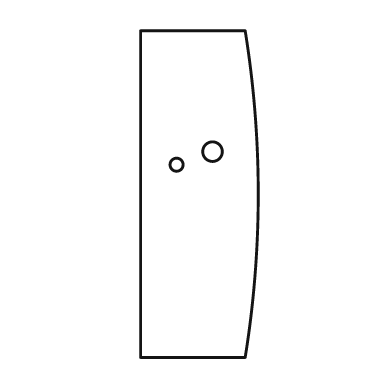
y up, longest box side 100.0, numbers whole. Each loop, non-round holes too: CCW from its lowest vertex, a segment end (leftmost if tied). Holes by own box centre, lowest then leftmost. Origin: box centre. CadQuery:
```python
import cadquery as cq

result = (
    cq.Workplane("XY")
    .moveTo(-18.0, -50.0)
    .lineTo(14.0, -50.0)
    .threePointArc((18.0, 0.0), (14.0, 50.0))
    .lineTo(-18.0, 50.0)
    .close()
    .moveTo(-7.0, 9.0)
    .circle(2.0)
    .moveTo(4.0, 13.0)
    .circle(3.0)
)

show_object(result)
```